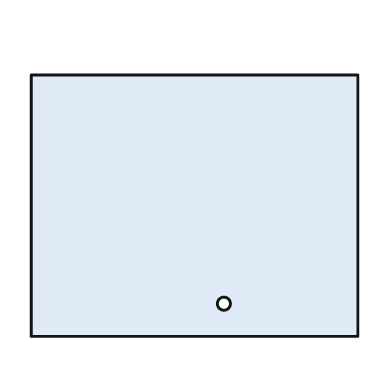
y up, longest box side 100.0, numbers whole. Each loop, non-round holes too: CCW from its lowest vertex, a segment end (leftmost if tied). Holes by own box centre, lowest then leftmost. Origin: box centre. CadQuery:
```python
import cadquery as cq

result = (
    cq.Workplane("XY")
    .moveTo(-50.0, -40.0)
    .lineTo(50.0, -40.0)
    .lineTo(50.0, 40.0)
    .lineTo(-50.0, 40.0)
    .close()
    .moveTo(9.0, -30.0)
    .circle(2.0)
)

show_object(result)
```